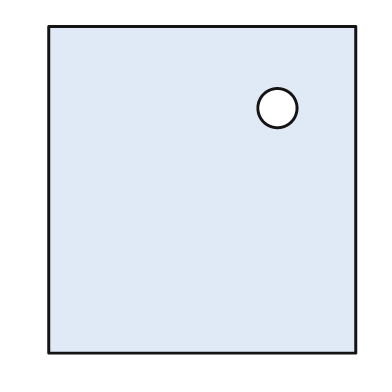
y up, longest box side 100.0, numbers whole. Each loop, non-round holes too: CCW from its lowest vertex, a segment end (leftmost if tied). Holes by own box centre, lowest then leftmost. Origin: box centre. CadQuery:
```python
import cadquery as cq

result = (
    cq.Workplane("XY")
    .moveTo(-47.0, -50.0)
    .lineTo(47.0, -50.0)
    .lineTo(47.0, 50.0)
    .lineTo(-47.0, 50.0)
    .close()
    .moveTo(23.0, 25.0)
    .circle(6.0)
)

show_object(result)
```